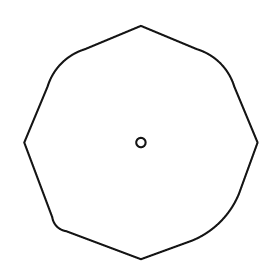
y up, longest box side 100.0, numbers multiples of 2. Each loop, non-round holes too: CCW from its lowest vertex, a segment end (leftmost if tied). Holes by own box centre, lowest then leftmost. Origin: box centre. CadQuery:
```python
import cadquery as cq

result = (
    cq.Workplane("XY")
    .moveTo(0.0, -50.0)
    .lineTo(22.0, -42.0)
    .threePointArc((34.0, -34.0), (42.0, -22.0))
    .lineTo(50.0, 0.0)
    .lineTo(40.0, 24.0)
    .threePointArc((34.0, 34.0), (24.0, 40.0))
    .lineTo(0.0, 50.0)
    .lineTo(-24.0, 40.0)
    .threePointArc((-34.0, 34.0), (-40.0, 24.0))
    .lineTo(-50.0, 0.0)
    .lineTo(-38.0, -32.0)
    .threePointArc((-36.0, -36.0), (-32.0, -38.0))
    .close()
    .moveTo(0.0, 0.0)
    .circle(2.0)
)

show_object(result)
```